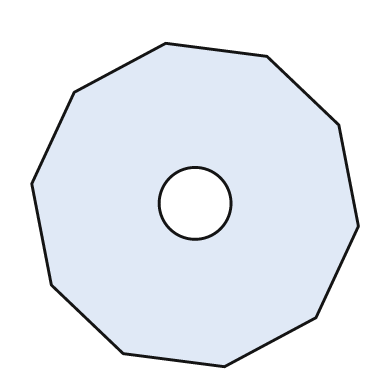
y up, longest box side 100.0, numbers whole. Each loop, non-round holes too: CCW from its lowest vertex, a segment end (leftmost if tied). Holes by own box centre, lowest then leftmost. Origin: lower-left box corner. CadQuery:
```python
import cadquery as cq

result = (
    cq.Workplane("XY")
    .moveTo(59.0, 0.0)
    .lineTo(87.0, 15.0)
    .lineTo(100.0, 43.0)
    .lineTo(94.0, 74.0)
    .lineTo(72.0, 95.0)
    .lineTo(41.0, 99.0)
    .lineTo(13.0, 84.0)
    .lineTo(0.0, 56.0)
    .lineTo(6.0, 25.0)
    .lineTo(28.0, 4.0)
    .close()
    .moveTo(50.0, 50.0)
    .circle(11.0)
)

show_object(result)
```